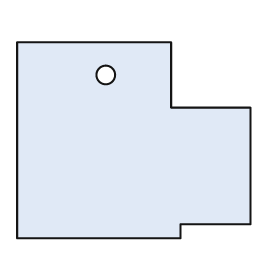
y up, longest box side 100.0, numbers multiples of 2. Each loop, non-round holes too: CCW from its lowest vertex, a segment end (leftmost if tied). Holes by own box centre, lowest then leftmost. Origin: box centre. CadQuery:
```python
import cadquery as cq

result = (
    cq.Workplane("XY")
    .moveTo(-50.0, -42.0)
    .lineTo(20.0, -42.0)
    .lineTo(20.0, -36.0)
    .lineTo(50.0, -36.0)
    .lineTo(50.0, 14.0)
    .lineTo(16.0, 14.0)
    .lineTo(16.0, 42.0)
    .lineTo(-50.0, 42.0)
    .close()
    .moveTo(-12.0, 28.0)
    .circle(4.0)
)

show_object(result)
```